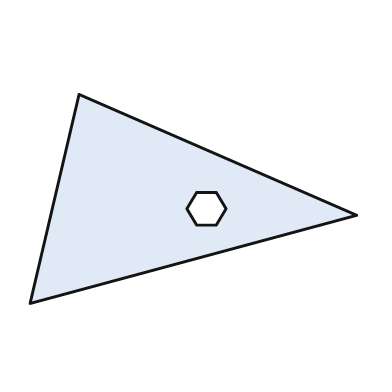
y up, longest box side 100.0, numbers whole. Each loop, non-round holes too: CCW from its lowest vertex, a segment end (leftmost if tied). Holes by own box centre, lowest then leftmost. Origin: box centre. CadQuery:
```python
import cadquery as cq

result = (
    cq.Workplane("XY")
    .moveTo(-50.0, -32.0)
    .lineTo(50.0, -5.0)
    .lineTo(-35.0, 32.0)
    .close()
    .moveTo(1.0, -8.0)
    .lineTo(7.0, -8.0)
    .lineTo(10.0, -3.0)
    .lineTo(7.0, 2.0)
    .lineTo(1.0, 2.0)
    .lineTo(-2.0, -3.0)
    .close()
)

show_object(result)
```